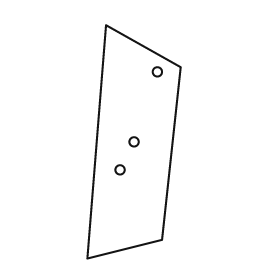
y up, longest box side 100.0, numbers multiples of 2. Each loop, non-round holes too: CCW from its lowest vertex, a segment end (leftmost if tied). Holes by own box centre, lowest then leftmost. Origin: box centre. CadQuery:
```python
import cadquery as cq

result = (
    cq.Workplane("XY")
    .moveTo(-20.0, -50.0)
    .lineTo(12.0, -42.0)
    .lineTo(20.0, 32.0)
    .lineTo(-12.0, 50.0)
    .close()
    .moveTo(-6.0, -12.0)
    .circle(2.0)
    .moveTo(0.0, 0.0)
    .circle(2.0)
    .moveTo(10.0, 30.0)
    .circle(2.0)
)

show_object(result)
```